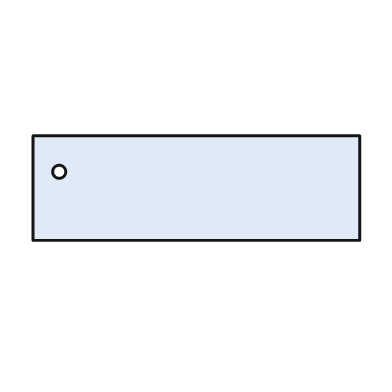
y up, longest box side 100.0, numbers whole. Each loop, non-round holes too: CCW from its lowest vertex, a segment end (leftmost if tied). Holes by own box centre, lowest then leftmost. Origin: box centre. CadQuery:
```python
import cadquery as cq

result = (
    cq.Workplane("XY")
    .moveTo(-50.0, -16.0)
    .lineTo(50.0, -16.0)
    .lineTo(50.0, 16.0)
    .lineTo(-50.0, 16.0)
    .close()
    .moveTo(-42.0, 5.0)
    .circle(2.0)
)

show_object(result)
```